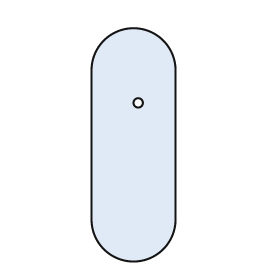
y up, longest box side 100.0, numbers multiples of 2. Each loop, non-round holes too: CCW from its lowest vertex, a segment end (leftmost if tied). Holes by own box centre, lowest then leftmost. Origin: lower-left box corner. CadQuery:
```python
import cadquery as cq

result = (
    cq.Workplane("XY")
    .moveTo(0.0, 18.0)
    .threePointArc((18.0, 0.0), (36.0, 18.0))
    .lineTo(36.0, 82.0)
    .threePointArc((18.0, 100.0), (0.0, 82.0))
    .close()
    .moveTo(20.0, 68.0)
    .circle(2.0)
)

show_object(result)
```